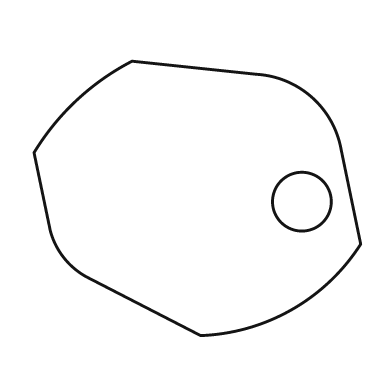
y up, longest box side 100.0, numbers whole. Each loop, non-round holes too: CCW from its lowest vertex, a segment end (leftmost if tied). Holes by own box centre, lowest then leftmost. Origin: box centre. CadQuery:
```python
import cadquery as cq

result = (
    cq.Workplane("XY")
    .moveTo(1.0, -42.0)
    .threePointArc((29.0, -34.0), (50.0, -14.0))
    .lineTo(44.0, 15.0)
    .threePointArc((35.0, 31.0), (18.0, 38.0))
    .lineTo(-20.0, 42.0)
    .threePointArc((-37.0, 30.0), (-50.0, 14.0))
    .lineTo(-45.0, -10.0)
    .threePointArc((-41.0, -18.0), (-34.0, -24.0))
    .close()
    .moveTo(32.0, -1.0)
    .circle(9.0)
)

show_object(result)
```